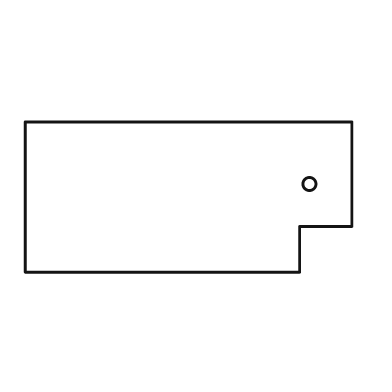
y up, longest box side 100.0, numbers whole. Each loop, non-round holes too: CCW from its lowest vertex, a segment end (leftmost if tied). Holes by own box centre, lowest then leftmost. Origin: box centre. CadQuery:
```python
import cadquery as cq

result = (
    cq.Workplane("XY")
    .moveTo(-50.0, -23.0)
    .lineTo(34.0, -23.0)
    .lineTo(34.0, -9.0)
    .lineTo(50.0, -9.0)
    .lineTo(50.0, 23.0)
    .lineTo(-50.0, 23.0)
    .close()
    .moveTo(37.0, 4.0)
    .circle(2.0)
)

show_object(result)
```